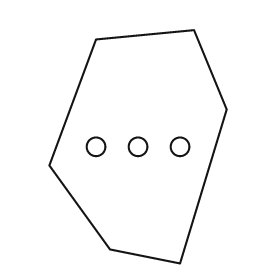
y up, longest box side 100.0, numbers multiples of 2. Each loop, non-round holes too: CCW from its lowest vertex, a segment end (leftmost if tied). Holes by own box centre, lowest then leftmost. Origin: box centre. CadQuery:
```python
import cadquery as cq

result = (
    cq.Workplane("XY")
    .moveTo(18.0, -50.0)
    .lineTo(38.0, 16.0)
    .lineTo(24.0, 50.0)
    .lineTo(-18.0, 46.0)
    .lineTo(-38.0, -8.0)
    .lineTo(-12.0, -44.0)
    .close()
    .moveTo(-18.0, 0.0)
    .circle(4.0)
    .moveTo(0.0, 0.0)
    .circle(4.0)
    .moveTo(18.0, 0.0)
    .circle(4.0)
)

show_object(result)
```